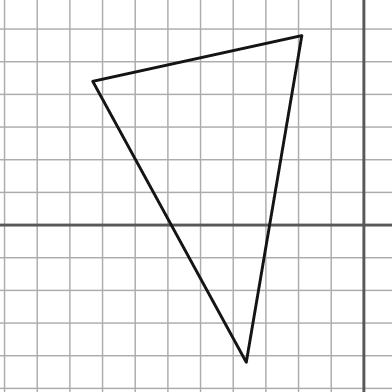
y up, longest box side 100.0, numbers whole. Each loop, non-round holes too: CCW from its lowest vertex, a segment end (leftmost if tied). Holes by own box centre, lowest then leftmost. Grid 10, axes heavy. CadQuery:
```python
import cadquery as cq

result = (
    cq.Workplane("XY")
    .moveTo(-36.0, -42.0)
    .lineTo(-19.0, 58.0)
    .lineTo(-83.0, 44.0)
    .close()
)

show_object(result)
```